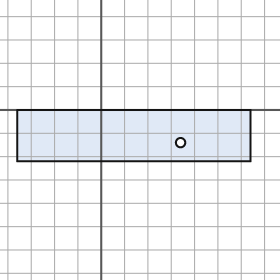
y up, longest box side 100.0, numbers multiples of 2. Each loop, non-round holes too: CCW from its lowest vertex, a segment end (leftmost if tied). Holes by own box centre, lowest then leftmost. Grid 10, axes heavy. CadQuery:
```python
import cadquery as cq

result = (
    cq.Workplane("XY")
    .moveTo(-36.0, -22.0)
    .lineTo(64.0, -22.0)
    .lineTo(64.0, 0.0)
    .lineTo(-36.0, 0.0)
    .close()
    .moveTo(34.0, -14.0)
    .circle(2.0)
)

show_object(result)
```